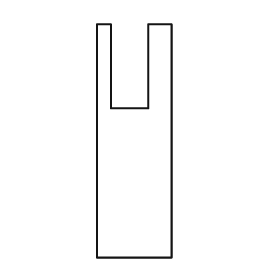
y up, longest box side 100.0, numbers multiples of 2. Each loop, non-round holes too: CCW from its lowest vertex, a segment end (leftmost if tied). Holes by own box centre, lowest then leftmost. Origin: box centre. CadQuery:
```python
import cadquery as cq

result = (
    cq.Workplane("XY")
    .moveTo(-16.0, -50.0)
    .lineTo(16.0, -50.0)
    .lineTo(16.0, 50.0)
    .lineTo(6.0, 50.0)
    .lineTo(6.0, 14.0)
    .lineTo(-10.0, 14.0)
    .lineTo(-10.0, 50.0)
    .lineTo(-16.0, 50.0)
    .close()
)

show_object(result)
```